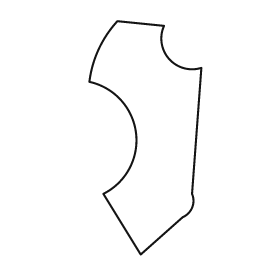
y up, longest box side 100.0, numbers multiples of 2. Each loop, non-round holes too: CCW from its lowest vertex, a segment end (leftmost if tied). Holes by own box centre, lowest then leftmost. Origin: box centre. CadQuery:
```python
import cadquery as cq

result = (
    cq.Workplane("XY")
    .moveTo(-2.0, -50.0)
    .lineTo(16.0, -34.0)
    .threePointArc((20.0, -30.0), (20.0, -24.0))
    .lineTo(24.0, 30.0)
    .threePointArc((10.0, 34.0), (8.0, 48.0))
    .lineTo(-12.0, 50.0)
    .threePointArc((-20.0, 38.0), (-24.0, 24.0))
    .threePointArc((-4.0, 2.0), (-18.0, -24.0))
    .close()
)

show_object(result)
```